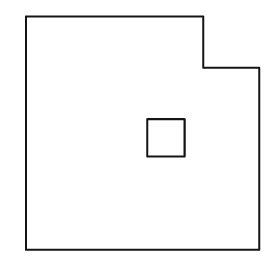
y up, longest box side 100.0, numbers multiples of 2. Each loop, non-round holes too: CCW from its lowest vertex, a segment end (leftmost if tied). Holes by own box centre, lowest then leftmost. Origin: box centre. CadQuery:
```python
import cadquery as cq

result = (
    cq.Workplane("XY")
    .moveTo(-50.0, -50.0)
    .lineTo(50.0, -50.0)
    .lineTo(50.0, 28.0)
    .lineTo(26.0, 28.0)
    .lineTo(26.0, 50.0)
    .lineTo(-50.0, 50.0)
    .close()
    .moveTo(2.0, -10.0)
    .lineTo(18.0, -10.0)
    .lineTo(18.0, 6.0)
    .lineTo(2.0, 6.0)
    .close()
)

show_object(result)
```